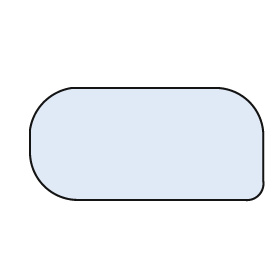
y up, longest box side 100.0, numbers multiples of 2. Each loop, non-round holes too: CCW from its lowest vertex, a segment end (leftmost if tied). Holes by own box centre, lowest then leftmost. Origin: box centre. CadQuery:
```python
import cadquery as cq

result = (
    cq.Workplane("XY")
    .moveTo(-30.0, -24.0)
    .lineTo(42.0, -24.0)
    .threePointArc((48.0, -22.0), (50.0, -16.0))
    .lineTo(50.0, 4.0)
    .threePointArc((44.0, 18.0), (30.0, 24.0))
    .lineTo(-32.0, 24.0)
    .threePointArc((-44.0, 18.0), (-50.0, 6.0))
    .lineTo(-50.0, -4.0)
    .threePointArc((-44.0, -18.0), (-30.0, -24.0))
    .close()
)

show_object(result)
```